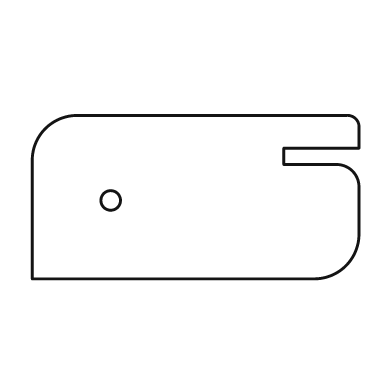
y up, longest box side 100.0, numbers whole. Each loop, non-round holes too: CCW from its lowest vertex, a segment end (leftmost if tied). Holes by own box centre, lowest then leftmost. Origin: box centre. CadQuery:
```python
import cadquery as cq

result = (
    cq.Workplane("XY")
    .moveTo(-50.0, -25.0)
    .lineTo(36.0, -25.0)
    .threePointArc((46.0, -21.0), (50.0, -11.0))
    .lineTo(50.0, 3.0)
    .threePointArc((48.0, 8.0), (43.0, 10.0))
    .lineTo(27.0, 10.0)
    .lineTo(27.0, 15.0)
    .lineTo(50.0, 15.0)
    .lineTo(50.0, 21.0)
    .threePointArc((49.0, 24.0), (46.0, 25.0))
    .lineTo(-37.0, 25.0)
    .threePointArc((-46.0, 21.0), (-50.0, 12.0))
    .close()
    .moveTo(-26.0, -1.0)
    .circle(3.0)
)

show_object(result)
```